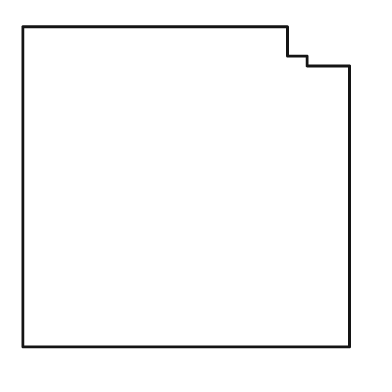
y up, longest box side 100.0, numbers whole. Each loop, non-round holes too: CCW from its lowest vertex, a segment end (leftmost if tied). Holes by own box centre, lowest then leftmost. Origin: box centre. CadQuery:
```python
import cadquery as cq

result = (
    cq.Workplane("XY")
    .moveTo(-50.0, -49.0)
    .lineTo(50.0, -49.0)
    .lineTo(50.0, 37.0)
    .lineTo(37.0, 37.0)
    .lineTo(37.0, 40.0)
    .lineTo(31.0, 40.0)
    .lineTo(31.0, 49.0)
    .lineTo(-50.0, 49.0)
    .close()
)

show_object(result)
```